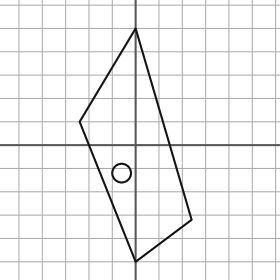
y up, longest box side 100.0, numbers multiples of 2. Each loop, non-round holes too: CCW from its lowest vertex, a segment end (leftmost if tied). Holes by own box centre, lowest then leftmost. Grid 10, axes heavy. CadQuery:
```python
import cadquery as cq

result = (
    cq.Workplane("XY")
    .moveTo(0.0, -50.0)
    .lineTo(24.0, -32.0)
    .lineTo(0.0, 50.0)
    .lineTo(-24.0, 10.0)
    .close()
    .moveTo(-6.0, -12.0)
    .circle(4.0)
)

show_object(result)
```